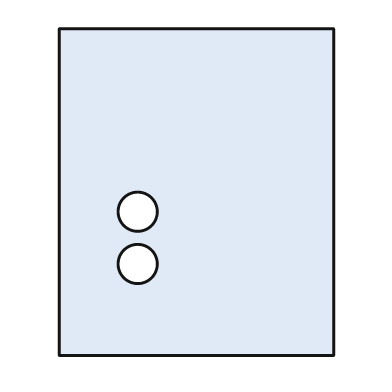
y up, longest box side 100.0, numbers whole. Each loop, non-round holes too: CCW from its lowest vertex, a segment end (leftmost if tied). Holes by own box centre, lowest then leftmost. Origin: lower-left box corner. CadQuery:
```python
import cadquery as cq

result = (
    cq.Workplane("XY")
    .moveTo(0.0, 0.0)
    .lineTo(84.0, 0.0)
    .lineTo(84.0, 100.0)
    .lineTo(0.0, 100.0)
    .close()
    .moveTo(24.0, 28.0)
    .circle(6.0)
    .moveTo(24.0, 44.0)
    .circle(6.0)
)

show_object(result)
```